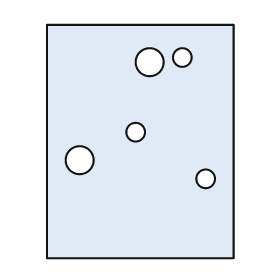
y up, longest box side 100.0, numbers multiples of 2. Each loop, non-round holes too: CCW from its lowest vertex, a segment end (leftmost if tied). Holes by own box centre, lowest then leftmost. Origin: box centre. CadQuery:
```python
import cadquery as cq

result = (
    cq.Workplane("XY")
    .moveTo(-40.0, -50.0)
    .lineTo(40.0, -50.0)
    .lineTo(40.0, 50.0)
    .lineTo(-40.0, 50.0)
    .close()
    .moveTo(28.0, -16.0)
    .circle(4.0)
    .moveTo(-26.0, -8.0)
    .circle(6.0)
    .moveTo(-2.0, 4.0)
    .circle(4.0)
    .moveTo(4.0, 34.0)
    .circle(6.0)
    .moveTo(18.0, 36.0)
    .circle(4.0)
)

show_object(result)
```